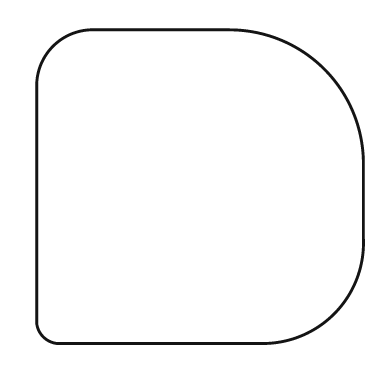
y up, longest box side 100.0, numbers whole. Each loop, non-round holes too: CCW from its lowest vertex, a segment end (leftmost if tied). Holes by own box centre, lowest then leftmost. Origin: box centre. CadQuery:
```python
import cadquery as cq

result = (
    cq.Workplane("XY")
    .moveTo(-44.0, -48.0)
    .lineTo(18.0, -48.0)
    .threePointArc((41.0, -39.0), (50.0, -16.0))
    .lineTo(50.0, 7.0)
    .threePointArc((38.0, 36.0), (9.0, 48.0))
    .lineTo(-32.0, 48.0)
    .threePointArc((-45.0, 43.0), (-50.0, 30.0))
    .lineTo(-50.0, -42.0)
    .threePointArc((-48.0, -46.0), (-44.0, -48.0))
    .close()
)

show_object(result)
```